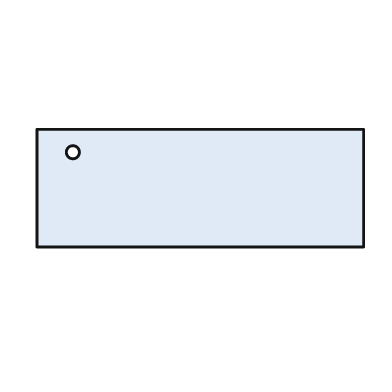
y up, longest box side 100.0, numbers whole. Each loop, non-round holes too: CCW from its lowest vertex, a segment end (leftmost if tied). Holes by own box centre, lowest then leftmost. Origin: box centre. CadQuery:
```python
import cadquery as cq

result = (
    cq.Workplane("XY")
    .moveTo(-50.0, -18.0)
    .lineTo(50.0, -18.0)
    .lineTo(50.0, 18.0)
    .lineTo(-50.0, 18.0)
    .close()
    .moveTo(-39.0, 11.0)
    .circle(2.0)
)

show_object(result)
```